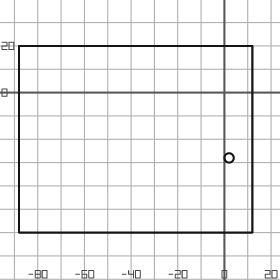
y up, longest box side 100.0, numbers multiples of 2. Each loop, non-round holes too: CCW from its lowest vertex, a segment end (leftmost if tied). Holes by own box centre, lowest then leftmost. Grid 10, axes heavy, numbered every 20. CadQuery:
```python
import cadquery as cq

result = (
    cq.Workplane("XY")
    .moveTo(-88.0, -60.0)
    .lineTo(12.0, -60.0)
    .lineTo(12.0, 20.0)
    .lineTo(-88.0, 20.0)
    .close()
    .moveTo(2.0, -28.0)
    .circle(2.0)
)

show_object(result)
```